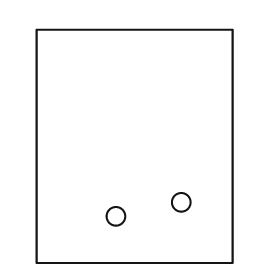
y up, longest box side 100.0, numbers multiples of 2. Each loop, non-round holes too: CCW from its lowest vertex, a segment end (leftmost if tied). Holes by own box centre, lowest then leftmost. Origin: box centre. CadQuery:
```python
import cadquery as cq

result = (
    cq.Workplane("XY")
    .moveTo(-42.0, -50.0)
    .lineTo(42.0, -50.0)
    .lineTo(42.0, 50.0)
    .lineTo(-42.0, 50.0)
    .close()
    .moveTo(-8.0, -30.0)
    .circle(4.0)
    .moveTo(20.0, -24.0)
    .circle(4.0)
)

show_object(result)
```